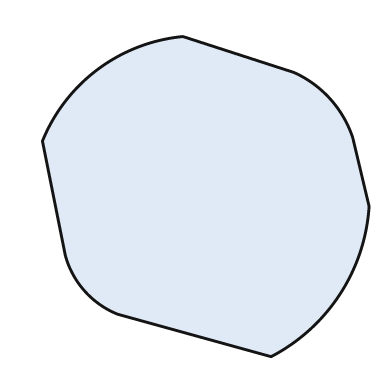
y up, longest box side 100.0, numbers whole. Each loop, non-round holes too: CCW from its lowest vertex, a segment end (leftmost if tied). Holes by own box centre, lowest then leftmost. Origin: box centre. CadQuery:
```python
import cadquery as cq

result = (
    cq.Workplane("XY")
    .moveTo(20.0, -49.0)
    .threePointArc((41.0, -30.0), (50.0, -3.0))
    .lineTo(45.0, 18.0)
    .threePointArc((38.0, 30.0), (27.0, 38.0))
    .lineTo(-7.0, 49.0)
    .threePointArc((-33.0, 39.0), (-50.0, 17.0))
    .lineTo(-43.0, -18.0)
    .threePointArc((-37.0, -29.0), (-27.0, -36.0))
    .close()
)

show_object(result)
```